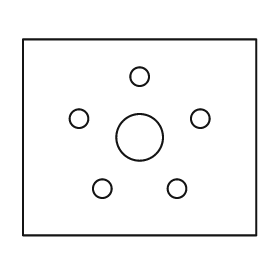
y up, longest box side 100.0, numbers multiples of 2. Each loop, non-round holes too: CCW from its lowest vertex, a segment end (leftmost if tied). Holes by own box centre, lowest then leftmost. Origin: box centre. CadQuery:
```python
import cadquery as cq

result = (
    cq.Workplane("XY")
    .moveTo(-50.0, -42.0)
    .lineTo(50.0, -42.0)
    .lineTo(50.0, 42.0)
    .lineTo(-50.0, 42.0)
    .close()
    .moveTo(-16.0, -22.0)
    .circle(4.0)
    .moveTo(16.0, -22.0)
    .circle(4.0)
    .moveTo(0.0, 0.0)
    .circle(10.0)
    .moveTo(-26.0, 8.0)
    .circle(4.0)
    .moveTo(26.0, 8.0)
    .circle(4.0)
    .moveTo(0.0, 26.0)
    .circle(4.0)
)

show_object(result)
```